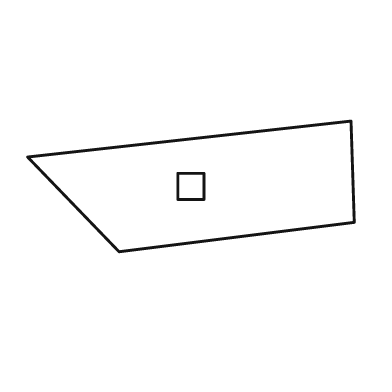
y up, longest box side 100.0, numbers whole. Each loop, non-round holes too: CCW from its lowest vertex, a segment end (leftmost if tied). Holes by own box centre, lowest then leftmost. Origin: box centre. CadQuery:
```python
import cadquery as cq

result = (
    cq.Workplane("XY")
    .moveTo(-22.0, -20.0)
    .lineTo(50.0, -11.0)
    .lineTo(49.0, 20.0)
    .lineTo(-50.0, 9.0)
    .close()
    .moveTo(-4.0, -4.0)
    .lineTo(4.0, -4.0)
    .lineTo(4.0, 4.0)
    .lineTo(-4.0, 4.0)
    .close()
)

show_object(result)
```